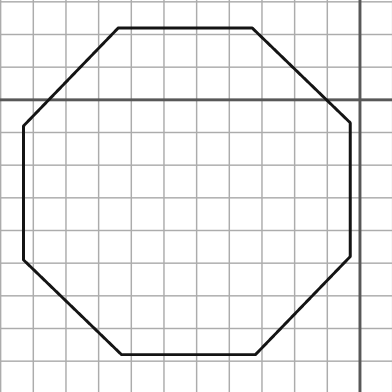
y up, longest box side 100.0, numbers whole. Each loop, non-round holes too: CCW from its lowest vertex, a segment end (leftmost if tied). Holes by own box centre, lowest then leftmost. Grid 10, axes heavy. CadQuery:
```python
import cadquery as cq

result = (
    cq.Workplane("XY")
    .moveTo(-73.0, -78.0)
    .lineTo(-32.0, -78.0)
    .lineTo(-3.0, -48.0)
    .lineTo(-3.0, -7.0)
    .lineTo(-33.0, 22.0)
    .lineTo(-74.0, 22.0)
    .lineTo(-103.0, -8.0)
    .lineTo(-103.0, -49.0)
    .close()
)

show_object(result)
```